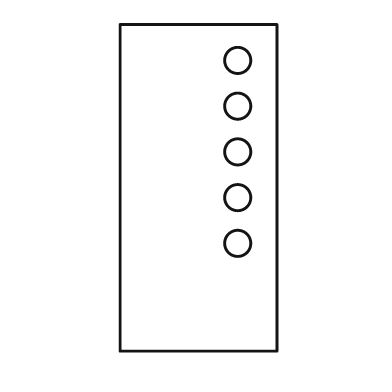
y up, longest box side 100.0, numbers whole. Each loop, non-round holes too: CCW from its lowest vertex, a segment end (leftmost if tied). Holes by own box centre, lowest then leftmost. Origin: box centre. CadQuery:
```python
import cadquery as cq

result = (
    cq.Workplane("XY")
    .moveTo(-24.0, -50.0)
    .lineTo(24.0, -50.0)
    .lineTo(24.0, 50.0)
    .lineTo(-24.0, 50.0)
    .close()
    .moveTo(12.0, -17.0)
    .circle(4.0)
    .moveTo(12.0, -3.0)
    .circle(4.0)
    .moveTo(12.0, 11.0)
    .circle(4.0)
    .moveTo(12.0, 25.0)
    .circle(4.0)
    .moveTo(12.0, 39.0)
    .circle(4.0)
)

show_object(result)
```